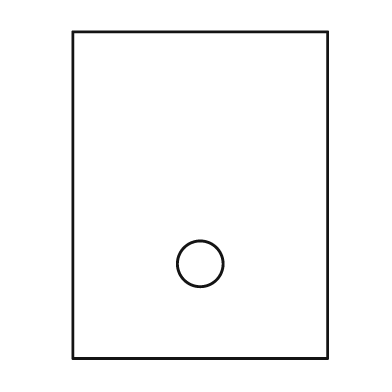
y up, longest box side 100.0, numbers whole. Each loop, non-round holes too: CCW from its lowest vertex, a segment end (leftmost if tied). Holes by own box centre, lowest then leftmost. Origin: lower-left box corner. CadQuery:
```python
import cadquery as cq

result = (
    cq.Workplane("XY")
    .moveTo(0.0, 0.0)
    .lineTo(78.0, 0.0)
    .lineTo(78.0, 100.0)
    .lineTo(0.0, 100.0)
    .close()
    .moveTo(39.0, 29.0)
    .circle(7.0)
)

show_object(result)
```